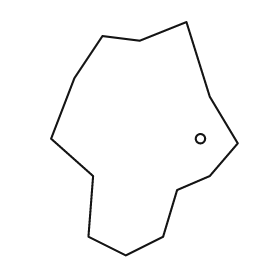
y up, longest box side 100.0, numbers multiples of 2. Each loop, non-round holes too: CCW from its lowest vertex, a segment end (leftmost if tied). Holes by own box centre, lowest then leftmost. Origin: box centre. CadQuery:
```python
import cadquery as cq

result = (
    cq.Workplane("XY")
    .moveTo(-8.0, -50.0)
    .lineTo(8.0, -42.0)
    .lineTo(14.0, -22.0)
    .lineTo(28.0, -16.0)
    .lineTo(40.0, -2.0)
    .lineTo(28.0, 18.0)
    .lineTo(18.0, 50.0)
    .lineTo(-2.0, 42.0)
    .lineTo(-18.0, 44.0)
    .lineTo(-30.0, 26.0)
    .lineTo(-40.0, 0.0)
    .lineTo(-22.0, -16.0)
    .lineTo(-24.0, -42.0)
    .close()
    .moveTo(24.0, 0.0)
    .circle(2.0)
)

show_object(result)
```